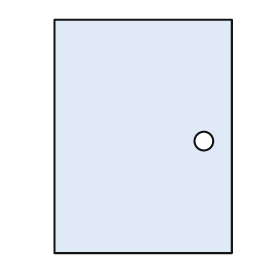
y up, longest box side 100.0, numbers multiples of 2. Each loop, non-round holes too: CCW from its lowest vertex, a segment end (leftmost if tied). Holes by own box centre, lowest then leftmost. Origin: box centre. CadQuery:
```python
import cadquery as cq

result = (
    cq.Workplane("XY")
    .moveTo(-38.0, -50.0)
    .lineTo(38.0, -50.0)
    .lineTo(38.0, 50.0)
    .lineTo(-38.0, 50.0)
    .close()
    .moveTo(26.0, -2.0)
    .circle(4.0)
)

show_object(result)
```